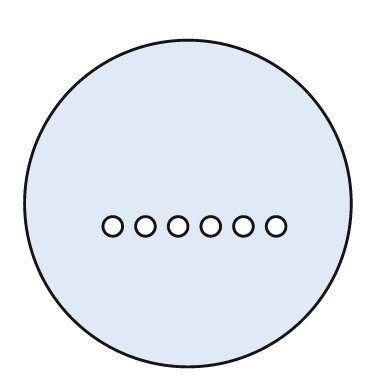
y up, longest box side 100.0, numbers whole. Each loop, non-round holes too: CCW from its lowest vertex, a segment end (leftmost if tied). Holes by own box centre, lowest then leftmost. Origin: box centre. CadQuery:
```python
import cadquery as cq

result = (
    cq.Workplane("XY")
    .moveTo(0.0, 0.0)
    .circle(50.0)
    .moveTo(-23.0, -7.0)
    .circle(3.0)
    .moveTo(-13.0, -7.0)
    .circle(3.0)
    .moveTo(-3.0, -7.0)
    .circle(3.0)
    .moveTo(7.0, -7.0)
    .circle(3.0)
    .moveTo(17.0, -7.0)
    .circle(3.0)
    .moveTo(27.0, -7.0)
    .circle(3.0)
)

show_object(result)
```